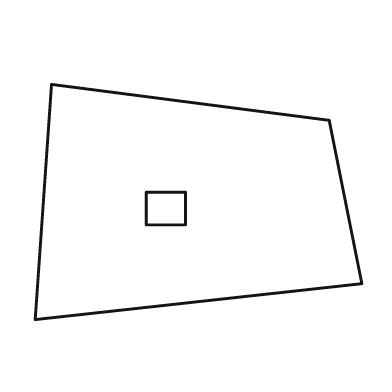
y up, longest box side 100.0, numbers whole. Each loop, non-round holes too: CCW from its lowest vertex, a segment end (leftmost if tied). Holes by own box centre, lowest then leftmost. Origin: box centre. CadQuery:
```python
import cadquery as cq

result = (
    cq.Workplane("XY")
    .moveTo(-50.0, -36.0)
    .lineTo(50.0, -25.0)
    .lineTo(40.0, 25.0)
    .lineTo(-45.0, 36.0)
    .close()
    .moveTo(-16.0, -7.0)
    .lineTo(-4.0, -7.0)
    .lineTo(-4.0, 3.0)
    .lineTo(-16.0, 3.0)
    .close()
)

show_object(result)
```